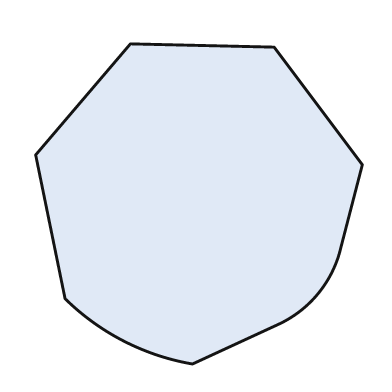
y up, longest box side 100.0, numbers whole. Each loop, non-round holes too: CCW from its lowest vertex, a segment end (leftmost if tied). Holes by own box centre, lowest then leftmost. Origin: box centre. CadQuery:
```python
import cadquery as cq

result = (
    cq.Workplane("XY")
    .moveTo(-2.0, -49.0)
    .lineTo(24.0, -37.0)
    .threePointArc((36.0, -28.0), (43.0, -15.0))
    .lineTo(50.0, 12.0)
    .lineTo(23.0, 48.0)
    .lineTo(-21.0, 49.0)
    .lineTo(-50.0, 15.0)
    .lineTo(-41.0, -29.0)
    .threePointArc((-23.0, -42.0), (-2.0, -49.0))
    .close()
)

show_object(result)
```